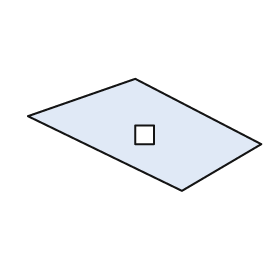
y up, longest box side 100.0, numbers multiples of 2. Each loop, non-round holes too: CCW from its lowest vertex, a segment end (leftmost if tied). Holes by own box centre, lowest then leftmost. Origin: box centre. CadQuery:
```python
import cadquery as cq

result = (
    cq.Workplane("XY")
    .moveTo(16.0, -24.0)
    .lineTo(50.0, -4.0)
    .lineTo(-4.0, 24.0)
    .lineTo(-50.0, 8.0)
    .close()
    .moveTo(-4.0, -4.0)
    .lineTo(4.0, -4.0)
    .lineTo(4.0, 4.0)
    .lineTo(-4.0, 4.0)
    .close()
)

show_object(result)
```